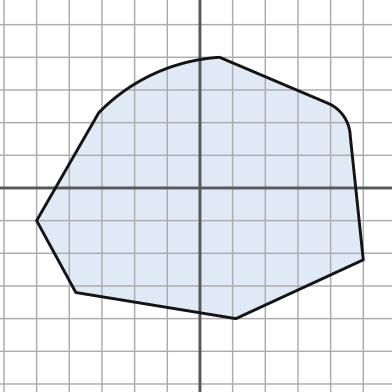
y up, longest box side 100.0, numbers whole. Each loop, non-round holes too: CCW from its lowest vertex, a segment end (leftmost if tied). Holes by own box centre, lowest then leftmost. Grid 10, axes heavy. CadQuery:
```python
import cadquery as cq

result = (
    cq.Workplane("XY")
    .moveTo(11.0, -40.0)
    .lineTo(50.0, -22.0)
    .lineTo(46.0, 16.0)
    .threePointArc((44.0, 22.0), (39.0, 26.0))
    .lineTo(6.0, 40.0)
    .threePointArc((-14.0, 35.0), (-31.0, 23.0))
    .lineTo(-50.0, -10.0)
    .lineTo(-38.0, -32.0)
    .close()
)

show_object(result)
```